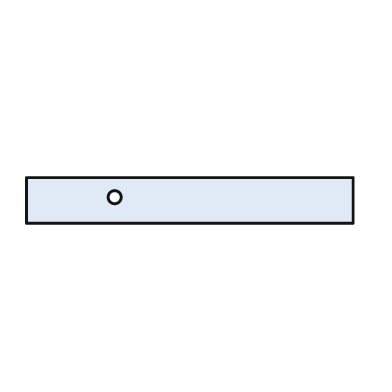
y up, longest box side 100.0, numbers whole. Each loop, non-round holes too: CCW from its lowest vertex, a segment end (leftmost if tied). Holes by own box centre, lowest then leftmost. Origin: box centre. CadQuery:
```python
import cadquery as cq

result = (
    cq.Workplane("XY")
    .moveTo(-50.0, -7.0)
    .lineTo(50.0, -7.0)
    .lineTo(50.0, 7.0)
    .lineTo(-50.0, 7.0)
    .close()
    .moveTo(-23.0, 1.0)
    .circle(2.0)
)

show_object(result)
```